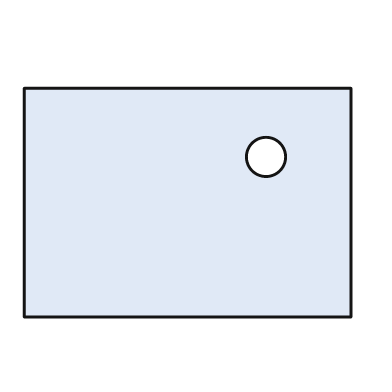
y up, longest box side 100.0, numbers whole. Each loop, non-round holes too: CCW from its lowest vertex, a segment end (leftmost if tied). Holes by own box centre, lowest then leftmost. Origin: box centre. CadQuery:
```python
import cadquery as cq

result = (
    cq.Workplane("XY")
    .moveTo(-50.0, -35.0)
    .lineTo(50.0, -35.0)
    .lineTo(50.0, 35.0)
    .lineTo(-50.0, 35.0)
    .close()
    .moveTo(24.0, 14.0)
    .circle(6.0)
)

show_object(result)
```